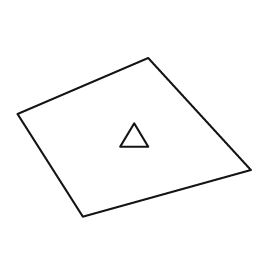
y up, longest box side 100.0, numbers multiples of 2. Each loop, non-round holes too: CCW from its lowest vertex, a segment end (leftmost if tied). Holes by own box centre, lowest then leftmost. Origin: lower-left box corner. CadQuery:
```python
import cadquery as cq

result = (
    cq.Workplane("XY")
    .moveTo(28.0, 0.0)
    .lineTo(100.0, 20.0)
    .lineTo(56.0, 68.0)
    .lineTo(0.0, 44.0)
    .close()
    .moveTo(44.0, 30.0)
    .lineTo(56.0, 30.0)
    .lineTo(50.0, 40.0)
    .close()
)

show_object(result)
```